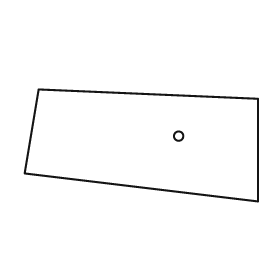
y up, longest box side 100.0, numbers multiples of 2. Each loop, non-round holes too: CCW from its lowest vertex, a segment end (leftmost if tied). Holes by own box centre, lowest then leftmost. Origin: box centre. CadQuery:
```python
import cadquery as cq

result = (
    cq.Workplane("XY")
    .moveTo(50.0, -24.0)
    .lineTo(50.0, 20.0)
    .lineTo(-44.0, 24.0)
    .lineTo(-50.0, -12.0)
    .close()
    .moveTo(16.0, 4.0)
    .circle(2.0)
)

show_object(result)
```